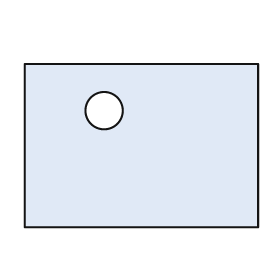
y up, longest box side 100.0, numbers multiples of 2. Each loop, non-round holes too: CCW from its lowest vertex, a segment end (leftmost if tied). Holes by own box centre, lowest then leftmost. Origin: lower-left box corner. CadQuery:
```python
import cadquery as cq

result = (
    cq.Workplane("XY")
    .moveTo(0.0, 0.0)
    .lineTo(100.0, 0.0)
    .lineTo(100.0, 70.0)
    .lineTo(0.0, 70.0)
    .close()
    .moveTo(34.0, 50.0)
    .circle(8.0)
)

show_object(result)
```